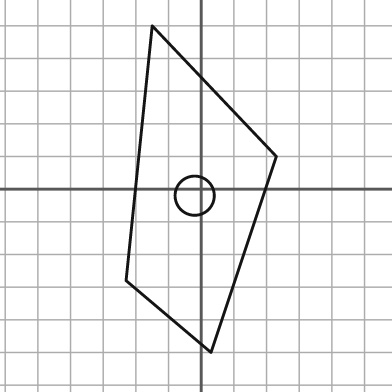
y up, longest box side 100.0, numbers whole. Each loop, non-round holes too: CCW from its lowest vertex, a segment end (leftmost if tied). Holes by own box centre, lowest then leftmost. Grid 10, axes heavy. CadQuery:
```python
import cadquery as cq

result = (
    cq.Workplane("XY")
    .moveTo(3.0, -50.0)
    .lineTo(23.0, 10.0)
    .lineTo(-15.0, 50.0)
    .lineTo(-23.0, -28.0)
    .close()
    .moveTo(-2.0, -2.0)
    .circle(6.0)
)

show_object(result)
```